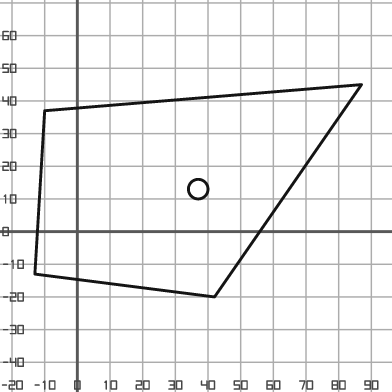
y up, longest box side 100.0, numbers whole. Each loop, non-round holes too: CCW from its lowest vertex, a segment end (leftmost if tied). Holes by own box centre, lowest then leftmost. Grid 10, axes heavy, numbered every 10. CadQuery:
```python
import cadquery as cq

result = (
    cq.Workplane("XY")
    .moveTo(42.0, -20.0)
    .lineTo(87.0, 45.0)
    .lineTo(-10.0, 37.0)
    .lineTo(-13.0, -13.0)
    .close()
    .moveTo(37.0, 13.0)
    .circle(3.0)
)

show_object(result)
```